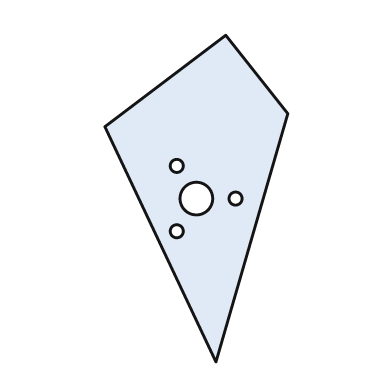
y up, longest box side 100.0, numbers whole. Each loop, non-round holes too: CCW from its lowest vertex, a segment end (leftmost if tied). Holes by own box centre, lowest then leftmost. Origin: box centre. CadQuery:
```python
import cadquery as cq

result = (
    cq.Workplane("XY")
    .moveTo(6.0, -50.0)
    .lineTo(28.0, 26.0)
    .lineTo(9.0, 50.0)
    .lineTo(-28.0, 22.0)
    .close()
    .moveTo(-6.0, -10.0)
    .circle(2.0)
    .moveTo(0.0, 0.0)
    .circle(5.0)
    .moveTo(12.0, 0.0)
    .circle(2.0)
    .moveTo(-6.0, 10.0)
    .circle(2.0)
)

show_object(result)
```